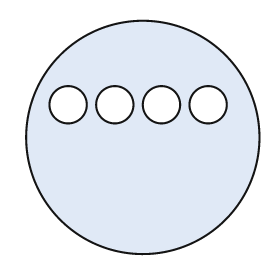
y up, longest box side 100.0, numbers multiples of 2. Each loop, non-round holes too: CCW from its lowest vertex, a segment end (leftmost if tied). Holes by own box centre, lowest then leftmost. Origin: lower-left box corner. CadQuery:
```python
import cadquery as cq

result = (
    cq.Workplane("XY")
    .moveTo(50.0, 50.0)
    .circle(50.0)
    .moveTo(18.0, 64.0)
    .circle(8.0)
    .moveTo(38.0, 64.0)
    .circle(8.0)
    .moveTo(58.0, 64.0)
    .circle(8.0)
    .moveTo(78.0, 64.0)
    .circle(8.0)
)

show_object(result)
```